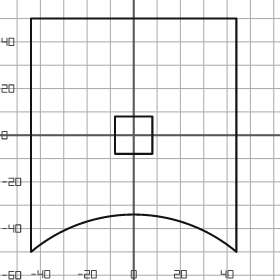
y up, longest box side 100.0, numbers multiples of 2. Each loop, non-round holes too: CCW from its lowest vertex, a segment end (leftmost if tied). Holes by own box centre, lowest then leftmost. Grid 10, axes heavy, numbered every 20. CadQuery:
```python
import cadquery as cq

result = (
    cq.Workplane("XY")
    .moveTo(-44.0, -50.0)
    .threePointArc((0.0, -34.0), (44.0, -50.0))
    .lineTo(44.0, 50.0)
    .lineTo(-44.0, 50.0)
    .close()
    .moveTo(-8.0, -8.0)
    .lineTo(8.0, -8.0)
    .lineTo(8.0, 8.0)
    .lineTo(-8.0, 8.0)
    .close()
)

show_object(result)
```